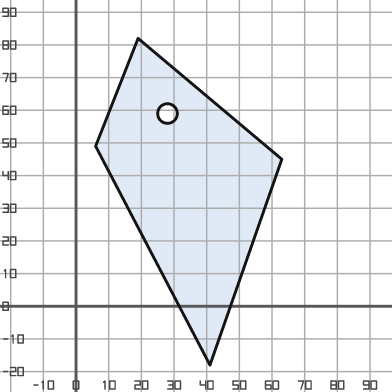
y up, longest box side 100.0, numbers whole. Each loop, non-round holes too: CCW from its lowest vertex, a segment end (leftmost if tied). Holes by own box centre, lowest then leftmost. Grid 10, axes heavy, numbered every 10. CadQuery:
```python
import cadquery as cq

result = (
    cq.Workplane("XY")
    .moveTo(41.0, -18.0)
    .lineTo(63.0, 45.0)
    .lineTo(19.0, 82.0)
    .lineTo(6.0, 49.0)
    .close()
    .moveTo(28.0, 59.0)
    .circle(3.0)
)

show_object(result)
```